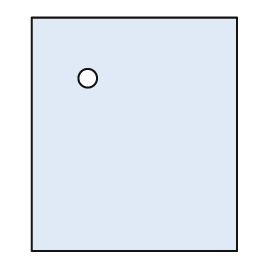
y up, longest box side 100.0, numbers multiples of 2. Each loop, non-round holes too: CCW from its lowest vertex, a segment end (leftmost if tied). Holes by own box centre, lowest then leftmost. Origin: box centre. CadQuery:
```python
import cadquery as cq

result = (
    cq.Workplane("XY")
    .moveTo(-44.0, -50.0)
    .lineTo(44.0, -50.0)
    .lineTo(44.0, 50.0)
    .lineTo(-44.0, 50.0)
    .close()
    .moveTo(-20.0, 24.0)
    .circle(4.0)
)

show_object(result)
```